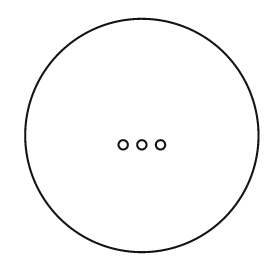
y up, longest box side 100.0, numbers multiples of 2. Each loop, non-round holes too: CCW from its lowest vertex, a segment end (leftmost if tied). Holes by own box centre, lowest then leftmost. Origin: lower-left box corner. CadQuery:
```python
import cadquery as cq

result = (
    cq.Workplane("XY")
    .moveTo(50.0, 50.0)
    .circle(50.0)
    .moveTo(42.0, 46.0)
    .circle(2.0)
    .moveTo(50.0, 46.0)
    .circle(2.0)
    .moveTo(58.0, 46.0)
    .circle(2.0)
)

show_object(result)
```